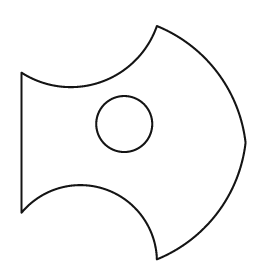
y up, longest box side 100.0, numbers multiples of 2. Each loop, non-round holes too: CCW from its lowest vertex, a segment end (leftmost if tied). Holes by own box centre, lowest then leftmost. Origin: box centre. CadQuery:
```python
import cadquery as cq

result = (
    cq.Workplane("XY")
    .moveTo(10.0, -50.0)
    .threePointArc((36.0, -30.0), (48.0, 0.0))
    .threePointArc((36.0, 30.0), (10.0, 50.0))
    .threePointArc((-14.0, 26.0), (-48.0, 30.0))
    .lineTo(-48.0, -30.0)
    .threePointArc((-12.0, -20.0), (10.0, -50.0))
    .close()
    .moveTo(-4.0, 8.0)
    .circle(12.0)
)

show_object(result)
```